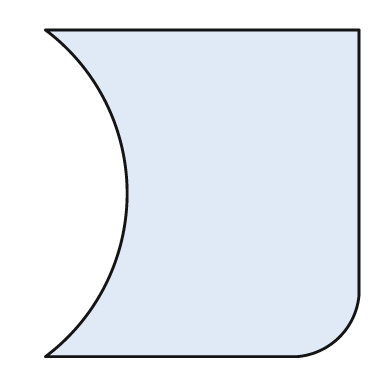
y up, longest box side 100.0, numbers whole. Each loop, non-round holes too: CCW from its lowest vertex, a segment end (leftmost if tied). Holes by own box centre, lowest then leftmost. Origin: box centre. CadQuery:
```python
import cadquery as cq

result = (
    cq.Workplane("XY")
    .moveTo(-48.0, -50.0)
    .lineTo(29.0, -50.0)
    .threePointArc((42.0, -44.0), (48.0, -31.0))
    .lineTo(48.0, 50.0)
    .lineTo(-48.0, 50.0)
    .threePointArc((-23.0, 0.0), (-48.0, -50.0))
    .close()
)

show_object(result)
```